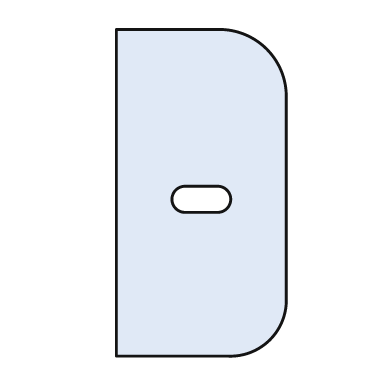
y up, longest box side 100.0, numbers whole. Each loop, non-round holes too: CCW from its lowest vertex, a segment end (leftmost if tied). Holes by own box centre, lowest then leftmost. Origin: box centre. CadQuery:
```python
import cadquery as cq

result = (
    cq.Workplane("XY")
    .moveTo(-26.0, -50.0)
    .lineTo(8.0, -50.0)
    .threePointArc((21.0, -45.0), (26.0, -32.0))
    .lineTo(26.0, 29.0)
    .threePointArc((20.0, 44.0), (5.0, 50.0))
    .lineTo(-26.0, 50.0)
    .close()
    .moveTo(-5.0, -6.0)
    .lineTo(5.0, -6.0)
    .threePointArc((9.0, -2.0), (5.0, 2.0))
    .lineTo(-5.0, 2.0)
    .threePointArc((-9.0, -2.0), (-5.0, -6.0))
    .close()
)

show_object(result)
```